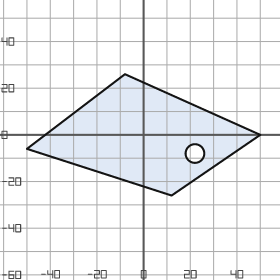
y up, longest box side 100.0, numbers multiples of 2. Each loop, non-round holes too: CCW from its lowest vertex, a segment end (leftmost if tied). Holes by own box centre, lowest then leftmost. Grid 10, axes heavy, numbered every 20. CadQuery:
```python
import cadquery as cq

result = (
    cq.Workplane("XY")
    .moveTo(12.0, -26.0)
    .lineTo(50.0, 0.0)
    .lineTo(-8.0, 26.0)
    .lineTo(-50.0, -6.0)
    .close()
    .moveTo(22.0, -8.0)
    .circle(4.0)
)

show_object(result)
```